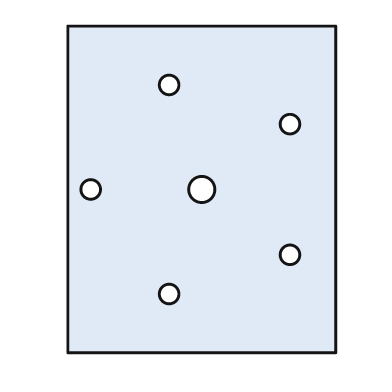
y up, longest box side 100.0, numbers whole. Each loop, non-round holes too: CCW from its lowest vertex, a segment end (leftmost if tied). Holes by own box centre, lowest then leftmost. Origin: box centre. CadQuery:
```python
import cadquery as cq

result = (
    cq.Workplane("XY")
    .moveTo(-41.0, -50.0)
    .lineTo(41.0, -50.0)
    .lineTo(41.0, 50.0)
    .lineTo(-41.0, 50.0)
    .close()
    .moveTo(-10.0, -32.0)
    .circle(3.0)
    .moveTo(27.0, -20.0)
    .circle(3.0)
    .moveTo(-34.0, 0.0)
    .circle(3.0)
    .moveTo(0.0, 0.0)
    .circle(4.0)
    .moveTo(27.0, 20.0)
    .circle(3.0)
    .moveTo(-10.0, 32.0)
    .circle(3.0)
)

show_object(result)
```